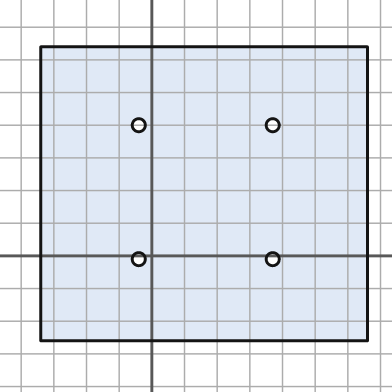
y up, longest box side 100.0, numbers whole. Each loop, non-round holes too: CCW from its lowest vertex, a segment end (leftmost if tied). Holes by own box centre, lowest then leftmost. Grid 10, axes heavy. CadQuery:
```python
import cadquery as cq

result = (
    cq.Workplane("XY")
    .moveTo(-34.0, -26.0)
    .lineTo(66.0, -26.0)
    .lineTo(66.0, 64.0)
    .lineTo(-34.0, 64.0)
    .close()
    .moveTo(-4.0, -1.0)
    .circle(2.0)
    .moveTo(37.0, -1.0)
    .circle(2.0)
    .moveTo(-4.0, 40.0)
    .circle(2.0)
    .moveTo(37.0, 40.0)
    .circle(2.0)
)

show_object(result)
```